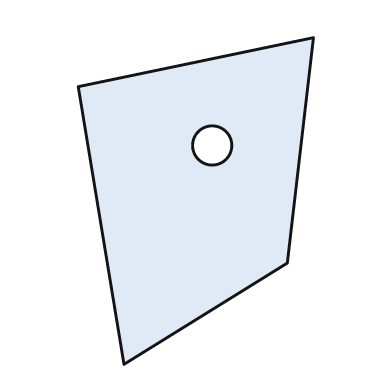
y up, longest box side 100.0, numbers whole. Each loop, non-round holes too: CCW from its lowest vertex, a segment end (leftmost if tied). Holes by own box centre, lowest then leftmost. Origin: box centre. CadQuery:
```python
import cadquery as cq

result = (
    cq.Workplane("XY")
    .moveTo(-22.0, -50.0)
    .lineTo(28.0, -19.0)
    .lineTo(36.0, 50.0)
    .lineTo(-36.0, 35.0)
    .close()
    .moveTo(5.0, 17.0)
    .circle(6.0)
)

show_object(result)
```